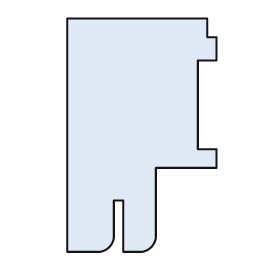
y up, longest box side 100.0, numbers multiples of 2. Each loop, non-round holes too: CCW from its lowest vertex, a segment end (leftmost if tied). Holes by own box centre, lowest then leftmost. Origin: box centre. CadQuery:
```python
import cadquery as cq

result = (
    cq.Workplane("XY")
    .moveTo(-32.0, -50.0)
    .lineTo(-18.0, -50.0)
    .threePointArc((-14.0, -48.0), (-12.0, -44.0))
    .lineTo(-12.0, -28.0)
    .lineTo(-8.0, -28.0)
    .lineTo(-8.0, -50.0)
    .lineTo(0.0, -50.0)
    .threePointArc((4.0, -48.0), (6.0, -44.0))
    .lineTo(6.0, -14.0)
    .lineTo(32.0, -14.0)
    .lineTo(32.0, -6.0)
    .lineTo(24.0, -6.0)
    .lineTo(24.0, 32.0)
    .lineTo(32.0, 32.0)
    .lineTo(32.0, 42.0)
    .lineTo(28.0, 42.0)
    .lineTo(28.0, 50.0)
    .lineTo(-32.0, 50.0)
    .close()
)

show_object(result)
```